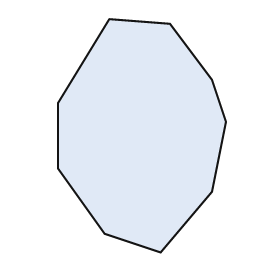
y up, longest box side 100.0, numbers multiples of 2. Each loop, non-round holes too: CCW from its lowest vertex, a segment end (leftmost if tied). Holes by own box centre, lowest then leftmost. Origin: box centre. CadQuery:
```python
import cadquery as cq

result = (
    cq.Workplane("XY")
    .moveTo(8.0, -50.0)
    .lineTo(30.0, -24.0)
    .lineTo(36.0, 6.0)
    .lineTo(30.0, 24.0)
    .lineTo(12.0, 48.0)
    .lineTo(-14.0, 50.0)
    .lineTo(-36.0, 14.0)
    .lineTo(-36.0, -14.0)
    .lineTo(-16.0, -42.0)
    .close()
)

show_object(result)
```